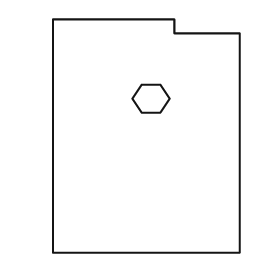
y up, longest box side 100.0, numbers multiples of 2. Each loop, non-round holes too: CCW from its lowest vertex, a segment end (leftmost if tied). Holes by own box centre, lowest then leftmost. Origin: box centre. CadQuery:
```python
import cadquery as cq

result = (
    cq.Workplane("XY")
    .moveTo(-40.0, -50.0)
    .lineTo(40.0, -50.0)
    .lineTo(40.0, 44.0)
    .lineTo(12.0, 44.0)
    .lineTo(12.0, 50.0)
    .lineTo(-40.0, 50.0)
    .close()
    .moveTo(-2.0, 10.0)
    .lineTo(6.0, 10.0)
    .lineTo(10.0, 16.0)
    .lineTo(6.0, 22.0)
    .lineTo(-2.0, 22.0)
    .lineTo(-6.0, 16.0)
    .close()
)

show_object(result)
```